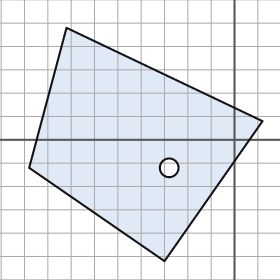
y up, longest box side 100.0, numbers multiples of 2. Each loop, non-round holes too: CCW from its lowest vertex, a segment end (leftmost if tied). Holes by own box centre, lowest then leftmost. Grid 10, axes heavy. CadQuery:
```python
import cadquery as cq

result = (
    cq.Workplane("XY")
    .moveTo(-30.0, -52.0)
    .lineTo(12.0, 8.0)
    .lineTo(-72.0, 48.0)
    .lineTo(-88.0, -12.0)
    .close()
    .moveTo(-28.0, -12.0)
    .circle(4.0)
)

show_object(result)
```